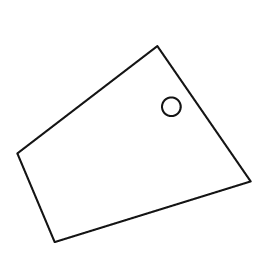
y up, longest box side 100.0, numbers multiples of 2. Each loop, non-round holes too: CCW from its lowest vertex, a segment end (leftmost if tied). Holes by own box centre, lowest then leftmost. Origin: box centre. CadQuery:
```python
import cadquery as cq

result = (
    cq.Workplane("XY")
    .moveTo(-34.0, -42.0)
    .lineTo(50.0, -16.0)
    .lineTo(10.0, 42.0)
    .lineTo(-50.0, -4.0)
    .close()
    .moveTo(16.0, 16.0)
    .circle(4.0)
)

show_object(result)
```